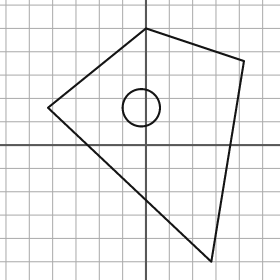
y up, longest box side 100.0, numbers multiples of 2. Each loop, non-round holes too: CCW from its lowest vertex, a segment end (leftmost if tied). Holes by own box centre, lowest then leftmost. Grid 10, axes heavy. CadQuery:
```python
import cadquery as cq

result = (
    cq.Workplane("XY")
    .moveTo(28.0, -50.0)
    .lineTo(42.0, 36.0)
    .lineTo(0.0, 50.0)
    .lineTo(-42.0, 16.0)
    .close()
    .moveTo(-2.0, 16.0)
    .circle(8.0)
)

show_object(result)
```